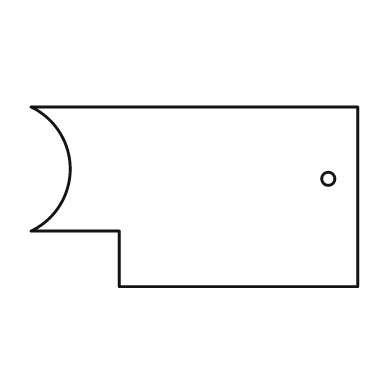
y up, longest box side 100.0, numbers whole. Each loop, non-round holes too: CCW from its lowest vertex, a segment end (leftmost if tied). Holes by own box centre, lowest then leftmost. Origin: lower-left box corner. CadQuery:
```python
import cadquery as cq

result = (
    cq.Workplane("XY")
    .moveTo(27.0, 0.0)
    .lineTo(100.0, 0.0)
    .lineTo(100.0, 55.0)
    .lineTo(0.0, 55.0)
    .threePointArc((12.0, 36.0), (0.0, 17.0))
    .lineTo(27.0, 17.0)
    .close()
    .moveTo(91.0, 33.0)
    .circle(2.0)
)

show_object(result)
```